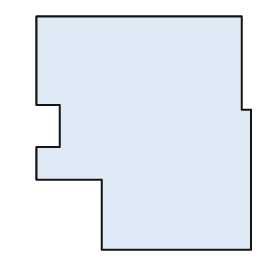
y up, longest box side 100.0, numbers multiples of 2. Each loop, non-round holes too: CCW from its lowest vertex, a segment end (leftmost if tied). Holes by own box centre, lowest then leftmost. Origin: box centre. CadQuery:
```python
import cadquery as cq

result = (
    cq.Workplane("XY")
    .moveTo(-18.0, -50.0)
    .lineTo(46.0, -50.0)
    .lineTo(46.0, 10.0)
    .lineTo(42.0, 10.0)
    .lineTo(42.0, 50.0)
    .lineTo(-46.0, 50.0)
    .lineTo(-46.0, 12.0)
    .lineTo(-36.0, 12.0)
    .lineTo(-36.0, -6.0)
    .lineTo(-46.0, -6.0)
    .lineTo(-46.0, -20.0)
    .lineTo(-18.0, -20.0)
    .close()
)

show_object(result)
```